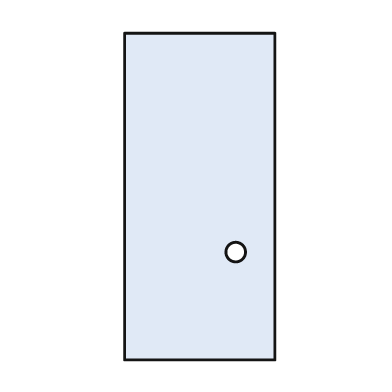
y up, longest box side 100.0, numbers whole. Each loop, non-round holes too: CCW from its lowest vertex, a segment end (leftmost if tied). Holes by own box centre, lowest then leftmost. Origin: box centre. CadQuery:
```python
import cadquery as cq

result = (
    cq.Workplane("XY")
    .moveTo(-23.0, -50.0)
    .lineTo(23.0, -50.0)
    .lineTo(23.0, 50.0)
    .lineTo(-23.0, 50.0)
    .close()
    .moveTo(11.0, -17.0)
    .circle(3.0)
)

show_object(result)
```